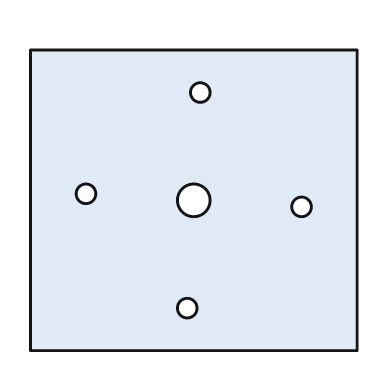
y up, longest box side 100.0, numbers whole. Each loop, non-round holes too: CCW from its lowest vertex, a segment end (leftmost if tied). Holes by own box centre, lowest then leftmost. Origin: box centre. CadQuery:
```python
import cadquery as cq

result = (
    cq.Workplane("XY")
    .moveTo(-50.0, -46.0)
    .lineTo(50.0, -46.0)
    .lineTo(50.0, 46.0)
    .lineTo(-50.0, 46.0)
    .close()
    .moveTo(-2.0, -33.0)
    .circle(3.0)
    .moveTo(33.0, -2.0)
    .circle(3.0)
    .moveTo(0.0, 0.0)
    .circle(5.0)
    .moveTo(-33.0, 2.0)
    .circle(3.0)
    .moveTo(2.0, 33.0)
    .circle(3.0)
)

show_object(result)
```